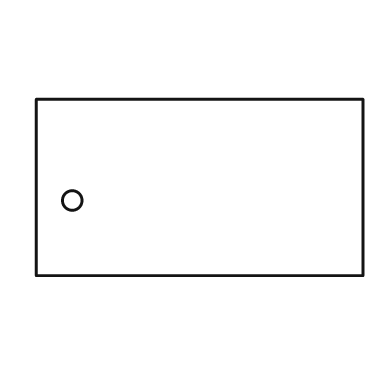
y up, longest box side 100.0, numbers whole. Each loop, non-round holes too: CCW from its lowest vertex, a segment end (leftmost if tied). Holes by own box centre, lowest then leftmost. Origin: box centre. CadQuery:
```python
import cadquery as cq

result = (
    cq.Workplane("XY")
    .moveTo(-50.0, -27.0)
    .lineTo(50.0, -27.0)
    .lineTo(50.0, 27.0)
    .lineTo(-50.0, 27.0)
    .close()
    .moveTo(-39.0, -4.0)
    .circle(3.0)
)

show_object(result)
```